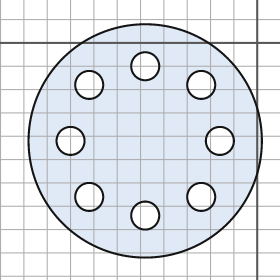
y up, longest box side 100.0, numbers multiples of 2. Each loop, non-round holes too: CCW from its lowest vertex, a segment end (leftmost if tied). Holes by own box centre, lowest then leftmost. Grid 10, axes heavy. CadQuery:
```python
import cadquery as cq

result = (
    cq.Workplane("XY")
    .moveTo(-48.0, -42.0)
    .circle(50.0)
    .moveTo(-48.0, -74.0)
    .circle(6.0)
    .moveTo(-72.0, -66.0)
    .circle(6.0)
    .moveTo(-24.0, -66.0)
    .circle(6.0)
    .moveTo(-80.0, -42.0)
    .circle(6.0)
    .moveTo(-16.0, -42.0)
    .circle(6.0)
    .moveTo(-72.0, -18.0)
    .circle(6.0)
    .moveTo(-24.0, -18.0)
    .circle(6.0)
    .moveTo(-48.0, -10.0)
    .circle(6.0)
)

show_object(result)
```